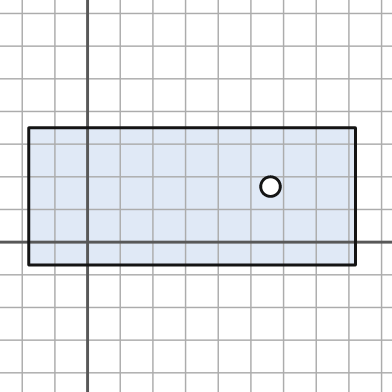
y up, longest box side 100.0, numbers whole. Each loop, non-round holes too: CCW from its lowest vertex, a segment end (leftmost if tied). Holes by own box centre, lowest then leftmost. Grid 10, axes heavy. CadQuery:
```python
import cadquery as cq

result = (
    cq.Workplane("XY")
    .moveTo(-18.0, -7.0)
    .lineTo(82.0, -7.0)
    .lineTo(82.0, 35.0)
    .lineTo(-18.0, 35.0)
    .close()
    .moveTo(56.0, 17.0)
    .circle(3.0)
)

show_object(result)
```